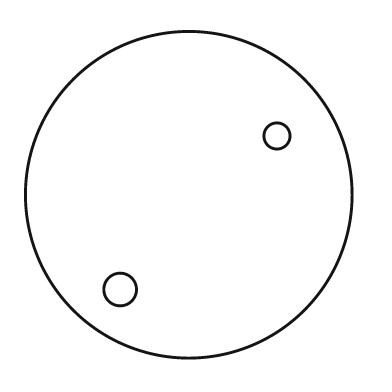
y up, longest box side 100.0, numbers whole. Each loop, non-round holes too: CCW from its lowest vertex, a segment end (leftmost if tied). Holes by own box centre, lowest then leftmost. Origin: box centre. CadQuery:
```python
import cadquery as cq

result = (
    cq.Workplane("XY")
    .moveTo(0.0, 0.0)
    .circle(50.0)
    .moveTo(-21.0, -29.0)
    .circle(5.0)
    .moveTo(27.0, 18.0)
    .circle(4.0)
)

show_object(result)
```